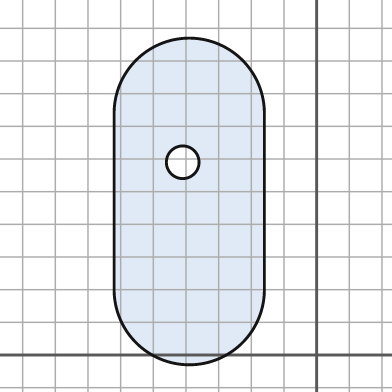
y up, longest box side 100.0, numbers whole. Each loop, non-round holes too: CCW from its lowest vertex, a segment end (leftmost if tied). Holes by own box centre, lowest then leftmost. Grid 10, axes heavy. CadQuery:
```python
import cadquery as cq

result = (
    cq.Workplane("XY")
    .moveTo(-62.0, 20.0)
    .threePointArc((-39.0, -3.0), (-16.0, 20.0))
    .lineTo(-16.0, 74.0)
    .threePointArc((-39.0, 97.0), (-62.0, 74.0))
    .close()
    .moveTo(-41.0, 59.0)
    .circle(5.0)
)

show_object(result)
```